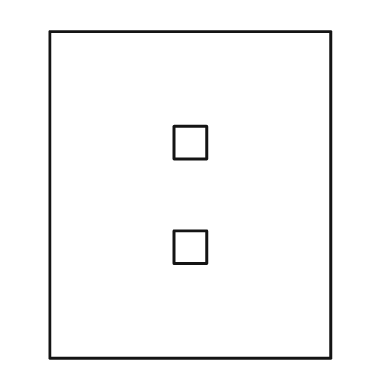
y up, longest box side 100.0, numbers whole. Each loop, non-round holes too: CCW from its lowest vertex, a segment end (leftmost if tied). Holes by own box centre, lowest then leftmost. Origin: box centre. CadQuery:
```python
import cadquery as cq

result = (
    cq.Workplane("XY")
    .moveTo(-43.0, -50.0)
    .lineTo(43.0, -50.0)
    .lineTo(43.0, 50.0)
    .lineTo(-43.0, 50.0)
    .close()
    .moveTo(-5.0, -21.0)
    .lineTo(5.0, -21.0)
    .lineTo(5.0, -11.0)
    .lineTo(-5.0, -11.0)
    .close()
    .moveTo(-5.0, 11.0)
    .lineTo(5.0, 11.0)
    .lineTo(5.0, 21.0)
    .lineTo(-5.0, 21.0)
    .close()
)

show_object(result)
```